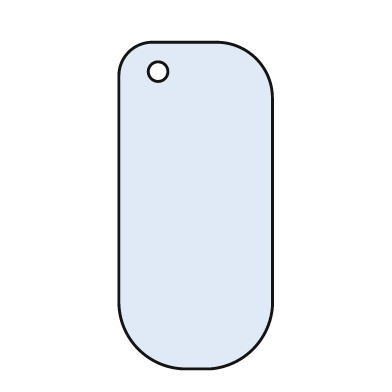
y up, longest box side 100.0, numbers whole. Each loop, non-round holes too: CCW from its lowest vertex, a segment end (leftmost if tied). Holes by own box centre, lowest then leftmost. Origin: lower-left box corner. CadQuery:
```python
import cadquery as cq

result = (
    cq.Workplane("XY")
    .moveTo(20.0, 0.0)
    .lineTo(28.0, 0.0)
    .threePointArc((41.0, 6.0), (47.0, 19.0))
    .lineTo(47.0, 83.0)
    .threePointArc((42.0, 95.0), (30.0, 100.0))
    .lineTo(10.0, 100.0)
    .threePointArc((3.0, 97.0), (0.0, 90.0))
    .lineTo(0.0, 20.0)
    .threePointArc((6.0, 6.0), (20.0, 0.0))
    .close()
    .moveTo(12.0, 91.0)
    .circle(3.0)
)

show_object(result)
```